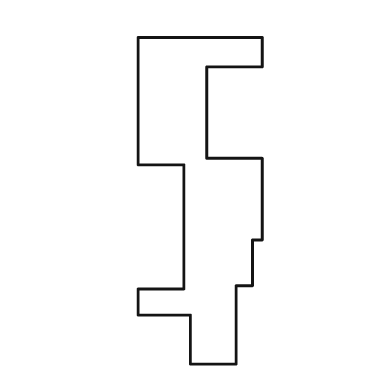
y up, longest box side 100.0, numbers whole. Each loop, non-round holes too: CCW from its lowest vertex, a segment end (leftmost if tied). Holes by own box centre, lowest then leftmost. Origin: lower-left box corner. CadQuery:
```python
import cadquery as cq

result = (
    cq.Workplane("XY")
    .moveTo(16.0, 0.0)
    .lineTo(30.0, 0.0)
    .lineTo(30.0, 24.0)
    .lineTo(35.0, 24.0)
    .lineTo(35.0, 38.0)
    .lineTo(38.0, 38.0)
    .lineTo(38.0, 63.0)
    .lineTo(21.0, 63.0)
    .lineTo(21.0, 91.0)
    .lineTo(38.0, 91.0)
    .lineTo(38.0, 100.0)
    .lineTo(0.0, 100.0)
    .lineTo(0.0, 61.0)
    .lineTo(14.0, 61.0)
    .lineTo(14.0, 23.0)
    .lineTo(0.0, 23.0)
    .lineTo(0.0, 15.0)
    .lineTo(16.0, 15.0)
    .close()
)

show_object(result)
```